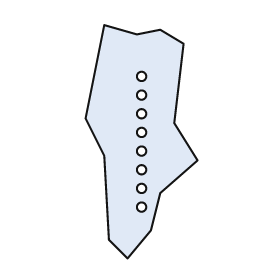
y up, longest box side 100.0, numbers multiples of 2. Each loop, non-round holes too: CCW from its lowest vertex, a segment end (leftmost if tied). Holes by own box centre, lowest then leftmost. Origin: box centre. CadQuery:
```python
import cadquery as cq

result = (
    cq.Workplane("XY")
    .moveTo(-6.0, -50.0)
    .lineTo(4.0, -38.0)
    .lineTo(8.0, -22.0)
    .lineTo(24.0, -8.0)
    .lineTo(14.0, 8.0)
    .lineTo(18.0, 42.0)
    .lineTo(8.0, 48.0)
    .lineTo(-2.0, 46.0)
    .lineTo(-16.0, 50.0)
    .lineTo(-24.0, 10.0)
    .lineTo(-16.0, -6.0)
    .lineTo(-14.0, -42.0)
    .close()
    .moveTo(0.0, -28.0)
    .circle(2.0)
    .moveTo(0.0, -20.0)
    .circle(2.0)
    .moveTo(0.0, -12.0)
    .circle(2.0)
    .moveTo(0.0, -4.0)
    .circle(2.0)
    .moveTo(0.0, 4.0)
    .circle(2.0)
    .moveTo(0.0, 12.0)
    .circle(2.0)
    .moveTo(0.0, 20.0)
    .circle(2.0)
    .moveTo(0.0, 28.0)
    .circle(2.0)
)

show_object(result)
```